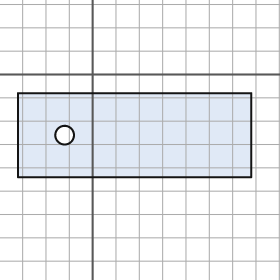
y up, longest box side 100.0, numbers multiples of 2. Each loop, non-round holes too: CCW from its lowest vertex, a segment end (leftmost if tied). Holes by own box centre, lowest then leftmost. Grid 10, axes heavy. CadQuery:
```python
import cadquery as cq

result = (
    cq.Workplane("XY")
    .moveTo(-32.0, -44.0)
    .lineTo(68.0, -44.0)
    .lineTo(68.0, -8.0)
    .lineTo(-32.0, -8.0)
    .close()
    .moveTo(-12.0, -26.0)
    .circle(4.0)
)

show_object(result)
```